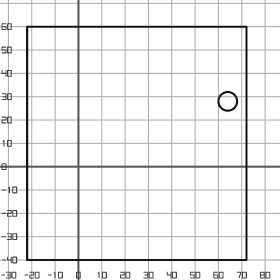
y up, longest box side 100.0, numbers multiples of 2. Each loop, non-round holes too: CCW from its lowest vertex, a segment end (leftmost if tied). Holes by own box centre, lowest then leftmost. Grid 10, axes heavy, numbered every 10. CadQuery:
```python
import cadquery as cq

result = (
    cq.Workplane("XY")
    .moveTo(-22.0, -40.0)
    .lineTo(72.0, -40.0)
    .lineTo(72.0, 60.0)
    .lineTo(-22.0, 60.0)
    .close()
    .moveTo(64.0, 28.0)
    .circle(4.0)
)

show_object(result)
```